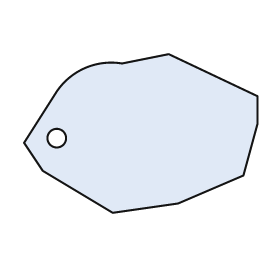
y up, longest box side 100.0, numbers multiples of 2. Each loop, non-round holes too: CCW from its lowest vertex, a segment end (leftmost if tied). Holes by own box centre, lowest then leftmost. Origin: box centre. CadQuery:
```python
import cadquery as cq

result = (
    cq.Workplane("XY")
    .moveTo(-12.0, -34.0)
    .lineTo(16.0, -30.0)
    .lineTo(44.0, -18.0)
    .lineTo(50.0, 4.0)
    .lineTo(50.0, 16.0)
    .lineTo(12.0, 34.0)
    .lineTo(-8.0, 30.0)
    .threePointArc((-24.0, 28.0), (-36.0, 18.0))
    .lineTo(-50.0, -4.0)
    .lineTo(-42.0, -16.0)
    .close()
    .moveTo(-36.0, -2.0)
    .circle(4.0)
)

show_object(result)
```